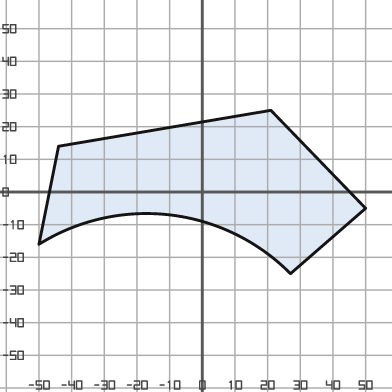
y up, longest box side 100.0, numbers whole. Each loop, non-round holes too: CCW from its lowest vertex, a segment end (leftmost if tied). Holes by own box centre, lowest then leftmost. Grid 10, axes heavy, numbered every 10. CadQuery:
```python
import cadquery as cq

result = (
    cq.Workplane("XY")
    .moveTo(27.0, -25.0)
    .lineTo(50.0, -5.0)
    .lineTo(21.0, 25.0)
    .lineTo(-44.0, 14.0)
    .lineTo(-50.0, -16.0)
    .threePointArc((-10.0, -7.0), (27.0, -25.0))
    .close()
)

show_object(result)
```